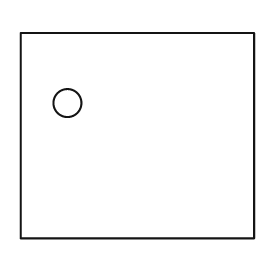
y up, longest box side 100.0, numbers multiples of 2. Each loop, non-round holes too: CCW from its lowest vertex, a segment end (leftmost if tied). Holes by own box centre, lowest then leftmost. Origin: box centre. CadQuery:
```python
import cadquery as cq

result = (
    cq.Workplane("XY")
    .moveTo(-50.0, -44.0)
    .lineTo(50.0, -44.0)
    .lineTo(50.0, 44.0)
    .lineTo(-50.0, 44.0)
    .close()
    .moveTo(-30.0, 14.0)
    .circle(6.0)
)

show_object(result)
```